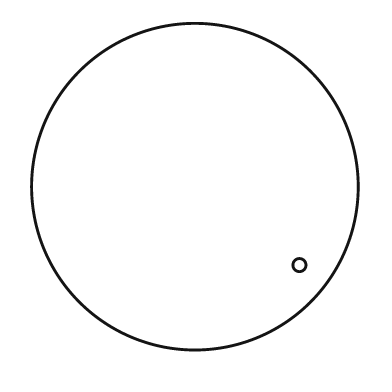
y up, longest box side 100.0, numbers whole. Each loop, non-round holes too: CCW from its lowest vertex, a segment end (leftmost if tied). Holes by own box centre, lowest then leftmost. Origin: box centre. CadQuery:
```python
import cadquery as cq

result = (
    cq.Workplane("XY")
    .moveTo(0.0, 0.0)
    .circle(50.0)
    .moveTo(32.0, -24.0)
    .circle(2.0)
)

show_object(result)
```